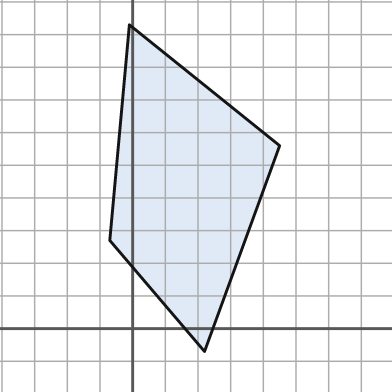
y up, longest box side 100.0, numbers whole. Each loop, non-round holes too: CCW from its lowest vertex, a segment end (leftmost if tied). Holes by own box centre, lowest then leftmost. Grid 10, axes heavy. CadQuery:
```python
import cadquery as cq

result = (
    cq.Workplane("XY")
    .moveTo(22.0, -7.0)
    .lineTo(45.0, 56.0)
    .lineTo(-1.0, 93.0)
    .lineTo(-7.0, 27.0)
    .close()
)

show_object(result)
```